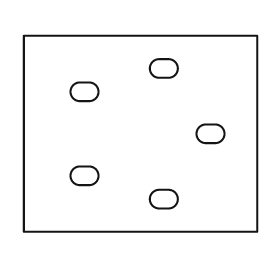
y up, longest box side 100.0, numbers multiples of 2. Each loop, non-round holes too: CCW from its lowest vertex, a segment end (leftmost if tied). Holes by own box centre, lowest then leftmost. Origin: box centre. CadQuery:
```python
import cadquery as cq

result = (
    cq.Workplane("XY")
    .moveTo(-50.0, -42.0)
    .lineTo(50.0, -42.0)
    .lineTo(50.0, 42.0)
    .lineTo(-50.0, 42.0)
    .close()
    .moveTo(8.0, -32.0)
    .lineTo(12.0, -32.0)
    .threePointArc((16.0, -28.0), (12.0, -24.0))
    .lineTo(8.0, -24.0)
    .threePointArc((4.0, -28.0), (8.0, -32.0))
    .close()
    .moveTo(-26.0, -22.0)
    .lineTo(-22.0, -22.0)
    .threePointArc((-18.0, -18.0), (-22.0, -14.0))
    .lineTo(-26.0, -14.0)
    .threePointArc((-30.0, -18.0), (-26.0, -22.0))
    .close()
    .moveTo(28.0, -4.0)
    .lineTo(32.0, -4.0)
    .threePointArc((36.0, 0.0), (32.0, 4.0))
    .lineTo(28.0, 4.0)
    .threePointArc((24.0, 0.0), (28.0, -4.0))
    .close()
    .moveTo(-26.0, 14.0)
    .lineTo(-22.0, 14.0)
    .threePointArc((-18.0, 18.0), (-22.0, 22.0))
    .lineTo(-26.0, 22.0)
    .threePointArc((-30.0, 18.0), (-26.0, 14.0))
    .close()
    .moveTo(8.0, 24.0)
    .lineTo(12.0, 24.0)
    .threePointArc((16.0, 28.0), (12.0, 32.0))
    .lineTo(8.0, 32.0)
    .threePointArc((4.0, 28.0), (8.0, 24.0))
    .close()
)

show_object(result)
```